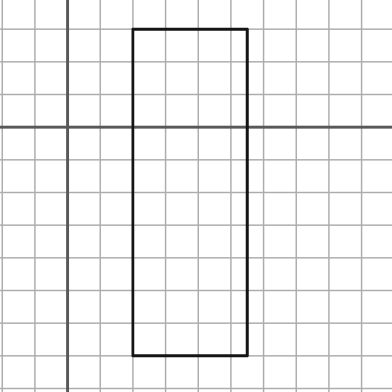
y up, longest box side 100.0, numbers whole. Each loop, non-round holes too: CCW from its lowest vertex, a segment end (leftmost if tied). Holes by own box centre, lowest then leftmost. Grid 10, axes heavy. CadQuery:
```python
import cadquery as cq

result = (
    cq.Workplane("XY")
    .moveTo(20.0, -70.0)
    .lineTo(55.0, -70.0)
    .lineTo(55.0, 30.0)
    .lineTo(20.0, 30.0)
    .close()
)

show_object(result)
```